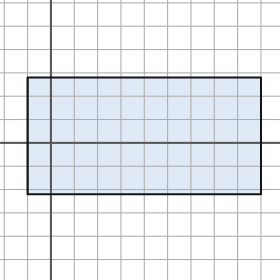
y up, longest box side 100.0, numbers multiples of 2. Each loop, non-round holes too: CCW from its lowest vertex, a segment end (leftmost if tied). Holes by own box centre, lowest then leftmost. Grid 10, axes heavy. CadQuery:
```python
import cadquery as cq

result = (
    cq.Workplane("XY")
    .moveTo(-10.0, -22.0)
    .lineTo(90.0, -22.0)
    .lineTo(90.0, 28.0)
    .lineTo(-10.0, 28.0)
    .close()
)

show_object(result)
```